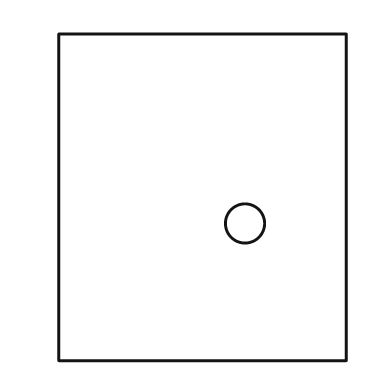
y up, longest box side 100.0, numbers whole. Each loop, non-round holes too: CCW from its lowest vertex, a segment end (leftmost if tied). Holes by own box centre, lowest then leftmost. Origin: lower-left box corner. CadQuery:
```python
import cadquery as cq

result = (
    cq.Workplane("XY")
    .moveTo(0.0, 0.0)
    .lineTo(88.0, 0.0)
    .lineTo(88.0, 100.0)
    .lineTo(0.0, 100.0)
    .close()
    .moveTo(57.0, 42.0)
    .circle(6.0)
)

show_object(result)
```